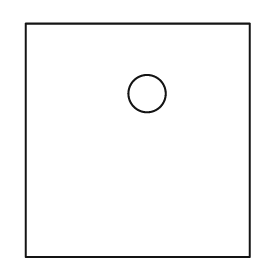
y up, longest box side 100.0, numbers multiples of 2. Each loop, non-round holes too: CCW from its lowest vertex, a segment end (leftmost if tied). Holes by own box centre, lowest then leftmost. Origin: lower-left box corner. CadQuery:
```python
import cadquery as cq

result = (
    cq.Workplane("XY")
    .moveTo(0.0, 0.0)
    .lineTo(96.0, 0.0)
    .lineTo(96.0, 100.0)
    .lineTo(0.0, 100.0)
    .close()
    .moveTo(52.0, 70.0)
    .circle(8.0)
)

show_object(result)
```